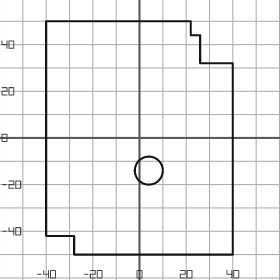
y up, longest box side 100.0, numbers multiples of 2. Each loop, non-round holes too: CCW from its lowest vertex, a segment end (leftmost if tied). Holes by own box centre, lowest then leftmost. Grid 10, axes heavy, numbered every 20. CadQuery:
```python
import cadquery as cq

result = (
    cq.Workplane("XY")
    .moveTo(-28.0, -50.0)
    .lineTo(40.0, -50.0)
    .lineTo(40.0, 32.0)
    .lineTo(26.0, 32.0)
    .lineTo(26.0, 44.0)
    .lineTo(22.0, 44.0)
    .lineTo(22.0, 50.0)
    .lineTo(-40.0, 50.0)
    .lineTo(-40.0, -42.0)
    .lineTo(-28.0, -42.0)
    .close()
    .moveTo(4.0, -14.0)
    .circle(6.0)
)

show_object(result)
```